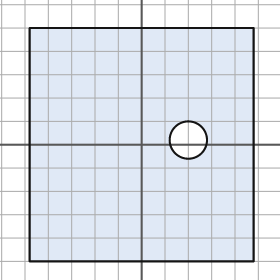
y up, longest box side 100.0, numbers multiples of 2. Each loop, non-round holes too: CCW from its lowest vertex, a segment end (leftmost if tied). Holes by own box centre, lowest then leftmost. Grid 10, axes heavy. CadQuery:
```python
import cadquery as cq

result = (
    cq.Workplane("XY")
    .moveTo(-48.0, -50.0)
    .lineTo(48.0, -50.0)
    .lineTo(48.0, 50.0)
    .lineTo(-48.0, 50.0)
    .close()
    .moveTo(20.0, 2.0)
    .circle(8.0)
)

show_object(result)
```